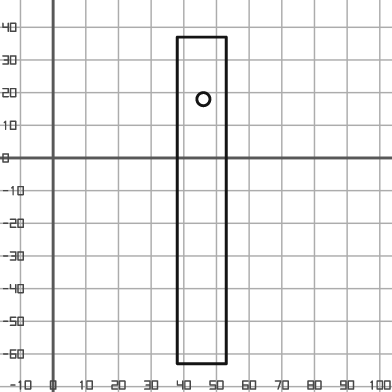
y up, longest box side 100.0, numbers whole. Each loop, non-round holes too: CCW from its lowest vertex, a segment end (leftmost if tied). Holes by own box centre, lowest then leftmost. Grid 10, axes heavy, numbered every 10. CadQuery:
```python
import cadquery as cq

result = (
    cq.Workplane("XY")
    .moveTo(38.0, -63.0)
    .lineTo(53.0, -63.0)
    .lineTo(53.0, 37.0)
    .lineTo(38.0, 37.0)
    .close()
    .moveTo(46.0, 18.0)
    .circle(2.0)
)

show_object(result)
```